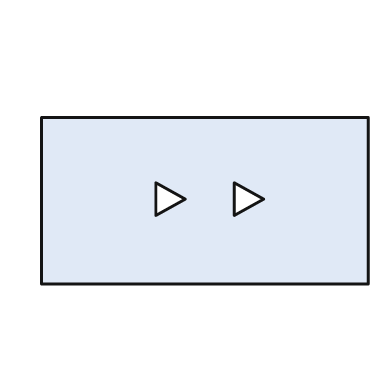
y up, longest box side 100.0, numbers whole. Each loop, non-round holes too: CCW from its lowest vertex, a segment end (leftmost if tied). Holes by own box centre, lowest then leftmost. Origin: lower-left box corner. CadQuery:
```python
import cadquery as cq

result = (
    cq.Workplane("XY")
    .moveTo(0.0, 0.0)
    .lineTo(100.0, 0.0)
    .lineTo(100.0, 51.0)
    .lineTo(0.0, 51.0)
    .close()
    .moveTo(35.0, 21.0)
    .lineTo(44.0, 26.0)
    .lineTo(35.0, 31.0)
    .close()
    .moveTo(59.0, 21.0)
    .lineTo(68.0, 26.0)
    .lineTo(59.0, 31.0)
    .close()
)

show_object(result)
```